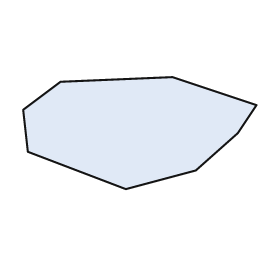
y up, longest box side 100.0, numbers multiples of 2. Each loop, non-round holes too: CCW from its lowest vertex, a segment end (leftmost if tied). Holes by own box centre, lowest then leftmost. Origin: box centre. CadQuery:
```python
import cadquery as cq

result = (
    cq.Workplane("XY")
    .moveTo(-6.0, -24.0)
    .lineTo(24.0, -16.0)
    .lineTo(42.0, 0.0)
    .lineTo(50.0, 12.0)
    .lineTo(14.0, 24.0)
    .lineTo(-34.0, 22.0)
    .lineTo(-50.0, 10.0)
    .lineTo(-48.0, -8.0)
    .close()
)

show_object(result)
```